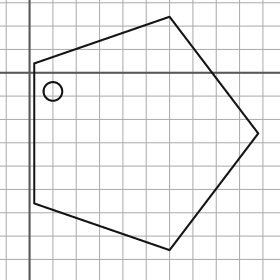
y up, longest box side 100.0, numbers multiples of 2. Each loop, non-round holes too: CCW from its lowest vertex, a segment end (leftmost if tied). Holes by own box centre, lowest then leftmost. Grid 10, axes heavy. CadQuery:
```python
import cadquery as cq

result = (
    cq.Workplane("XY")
    .moveTo(60.0, -76.0)
    .lineTo(98.0, -26.0)
    .lineTo(60.0, 24.0)
    .lineTo(2.0, 4.0)
    .lineTo(2.0, -56.0)
    .close()
    .moveTo(10.0, -8.0)
    .circle(4.0)
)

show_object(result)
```